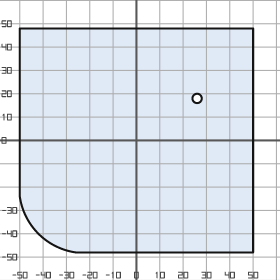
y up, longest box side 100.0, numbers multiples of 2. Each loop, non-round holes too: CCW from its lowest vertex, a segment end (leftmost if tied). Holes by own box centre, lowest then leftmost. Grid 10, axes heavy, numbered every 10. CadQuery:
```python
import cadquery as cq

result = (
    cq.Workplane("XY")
    .moveTo(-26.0, -48.0)
    .lineTo(50.0, -48.0)
    .lineTo(50.0, 48.0)
    .lineTo(-50.0, 48.0)
    .lineTo(-50.0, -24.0)
    .threePointArc((-42.0, -40.0), (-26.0, -48.0))
    .close()
    .moveTo(26.0, 18.0)
    .circle(2.0)
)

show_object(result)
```